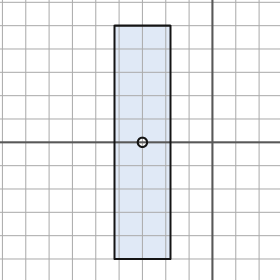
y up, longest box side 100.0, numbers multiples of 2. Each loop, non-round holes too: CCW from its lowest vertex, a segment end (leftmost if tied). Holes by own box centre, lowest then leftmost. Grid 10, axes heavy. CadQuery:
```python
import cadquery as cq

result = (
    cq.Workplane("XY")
    .moveTo(-42.0, -50.0)
    .lineTo(-18.0, -50.0)
    .lineTo(-18.0, 50.0)
    .lineTo(-42.0, 50.0)
    .close()
    .moveTo(-30.0, 0.0)
    .circle(2.0)
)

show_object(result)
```